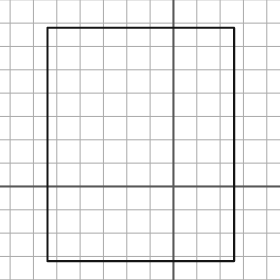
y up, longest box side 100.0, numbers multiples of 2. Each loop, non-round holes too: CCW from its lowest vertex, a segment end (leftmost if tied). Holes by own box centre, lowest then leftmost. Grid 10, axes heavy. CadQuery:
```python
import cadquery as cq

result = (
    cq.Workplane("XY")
    .moveTo(-54.0, -32.0)
    .lineTo(26.0, -32.0)
    .lineTo(26.0, 68.0)
    .lineTo(-54.0, 68.0)
    .close()
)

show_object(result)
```